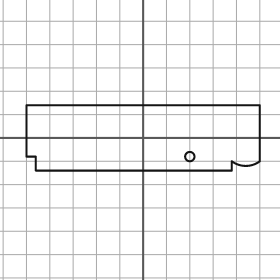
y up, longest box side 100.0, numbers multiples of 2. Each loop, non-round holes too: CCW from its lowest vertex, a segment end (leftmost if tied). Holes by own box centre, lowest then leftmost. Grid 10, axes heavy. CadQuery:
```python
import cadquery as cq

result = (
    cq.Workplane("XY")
    .moveTo(-46.0, -14.0)
    .lineTo(38.0, -14.0)
    .lineTo(38.0, -10.0)
    .threePointArc((44.0, -12.0), (50.0, -10.0))
    .lineTo(50.0, 14.0)
    .lineTo(-50.0, 14.0)
    .lineTo(-50.0, -8.0)
    .lineTo(-46.0, -8.0)
    .close()
    .moveTo(20.0, -8.0)
    .circle(2.0)
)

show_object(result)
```